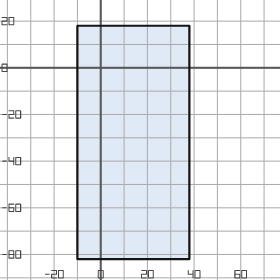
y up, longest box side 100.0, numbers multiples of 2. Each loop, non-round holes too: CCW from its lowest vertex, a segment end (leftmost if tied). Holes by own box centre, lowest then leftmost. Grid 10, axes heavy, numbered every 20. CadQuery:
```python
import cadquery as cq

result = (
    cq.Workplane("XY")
    .moveTo(-10.0, -82.0)
    .lineTo(38.0, -82.0)
    .lineTo(38.0, 18.0)
    .lineTo(-10.0, 18.0)
    .close()
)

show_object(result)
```